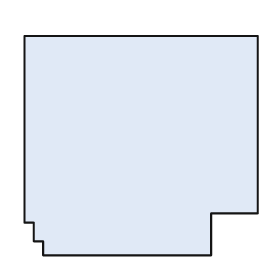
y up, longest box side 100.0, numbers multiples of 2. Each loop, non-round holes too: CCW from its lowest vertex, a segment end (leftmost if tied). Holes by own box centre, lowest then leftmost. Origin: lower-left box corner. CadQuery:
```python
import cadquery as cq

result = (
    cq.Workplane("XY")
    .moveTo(8.0, 0.0)
    .lineTo(80.0, 0.0)
    .lineTo(80.0, 18.0)
    .lineTo(100.0, 18.0)
    .lineTo(100.0, 94.0)
    .lineTo(0.0, 94.0)
    .lineTo(0.0, 14.0)
    .lineTo(4.0, 14.0)
    .lineTo(4.0, 6.0)
    .lineTo(8.0, 6.0)
    .close()
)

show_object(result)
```